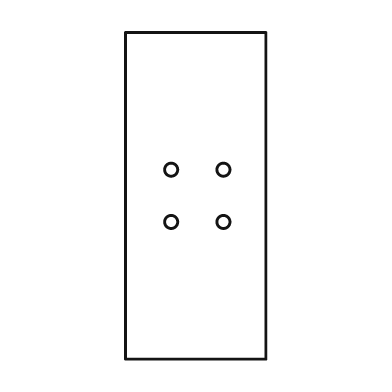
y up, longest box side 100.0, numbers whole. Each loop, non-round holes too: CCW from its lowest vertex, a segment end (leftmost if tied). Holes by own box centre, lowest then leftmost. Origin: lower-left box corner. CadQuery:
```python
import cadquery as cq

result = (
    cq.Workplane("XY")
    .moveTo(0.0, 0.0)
    .lineTo(43.0, 0.0)
    .lineTo(43.0, 100.0)
    .lineTo(0.0, 100.0)
    .close()
    .moveTo(14.0, 42.0)
    .circle(2.0)
    .moveTo(30.0, 42.0)
    .circle(2.0)
    .moveTo(14.0, 58.0)
    .circle(2.0)
    .moveTo(30.0, 58.0)
    .circle(2.0)
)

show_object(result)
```